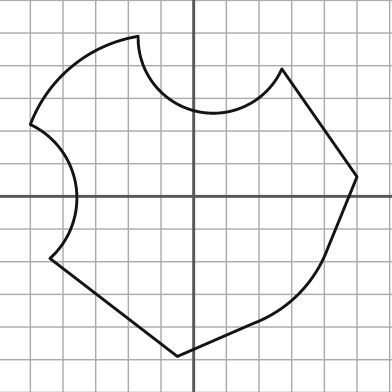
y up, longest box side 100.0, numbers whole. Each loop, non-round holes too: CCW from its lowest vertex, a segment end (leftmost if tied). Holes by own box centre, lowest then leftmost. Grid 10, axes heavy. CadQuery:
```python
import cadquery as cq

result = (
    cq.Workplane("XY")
    .moveTo(-5.0, -49.0)
    .lineTo(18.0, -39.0)
    .threePointArc((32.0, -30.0), (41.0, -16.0))
    .lineTo(50.0, 6.0)
    .lineTo(27.0, 39.0)
    .threePointArc((1.0, 26.0), (-17.0, 49.0))
    .threePointArc((-37.0, 40.0), (-50.0, 22.0))
    .threePointArc((-36.0, 3.0), (-44.0, -19.0))
    .close()
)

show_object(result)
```